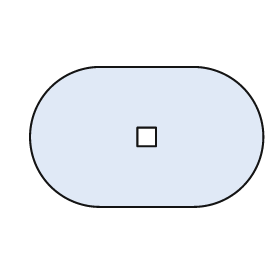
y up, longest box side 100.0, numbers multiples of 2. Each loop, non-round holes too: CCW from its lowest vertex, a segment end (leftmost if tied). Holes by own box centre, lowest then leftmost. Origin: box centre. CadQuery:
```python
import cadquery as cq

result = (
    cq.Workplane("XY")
    .moveTo(-20.0, -30.0)
    .lineTo(20.0, -30.0)
    .threePointArc((50.0, 0.0), (20.0, 30.0))
    .lineTo(-20.0, 30.0)
    .threePointArc((-50.0, 0.0), (-20.0, -30.0))
    .close()
    .moveTo(-4.0, -4.0)
    .lineTo(4.0, -4.0)
    .lineTo(4.0, 4.0)
    .lineTo(-4.0, 4.0)
    .close()
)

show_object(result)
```